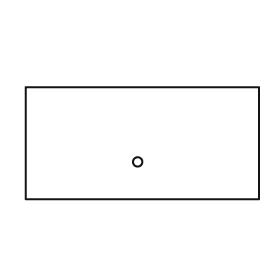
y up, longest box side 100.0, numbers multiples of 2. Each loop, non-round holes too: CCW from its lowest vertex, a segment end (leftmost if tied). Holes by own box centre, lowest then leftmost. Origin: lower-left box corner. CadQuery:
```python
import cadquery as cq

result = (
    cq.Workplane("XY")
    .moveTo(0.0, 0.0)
    .lineTo(100.0, 0.0)
    .lineTo(100.0, 48.0)
    .lineTo(0.0, 48.0)
    .close()
    .moveTo(48.0, 16.0)
    .circle(2.0)
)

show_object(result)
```